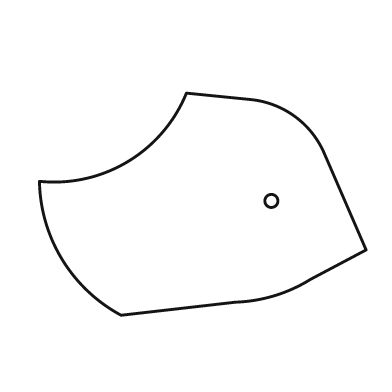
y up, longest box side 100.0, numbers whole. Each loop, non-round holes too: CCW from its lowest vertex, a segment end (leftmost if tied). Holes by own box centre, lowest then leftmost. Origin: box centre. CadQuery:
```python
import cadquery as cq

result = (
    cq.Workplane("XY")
    .moveTo(-25.0, -34.0)
    .lineTo(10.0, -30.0)
    .threePointArc((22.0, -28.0), (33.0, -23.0))
    .lineTo(50.0, -14.0)
    .lineTo(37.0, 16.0)
    .threePointArc((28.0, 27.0), (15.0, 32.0))
    .lineTo(-5.0, 34.0)
    .threePointArc((-23.0, 13.0), (-50.0, 7.0))
    .threePointArc((-43.0, -17.0), (-25.0, -34.0))
    .close()
    .moveTo(21.0, 1.0)
    .circle(2.0)
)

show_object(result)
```